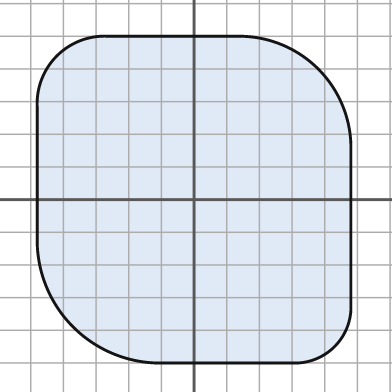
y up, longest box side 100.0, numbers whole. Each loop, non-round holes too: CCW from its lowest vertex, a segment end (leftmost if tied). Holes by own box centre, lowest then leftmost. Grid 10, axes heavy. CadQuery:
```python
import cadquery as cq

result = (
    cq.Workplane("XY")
    .moveTo(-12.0, -50.0)
    .lineTo(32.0, -50.0)
    .threePointArc((43.0, -45.0), (48.0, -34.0))
    .lineTo(48.0, 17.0)
    .threePointArc((38.0, 40.0), (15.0, 50.0))
    .lineTo(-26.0, 50.0)
    .threePointArc((-42.0, 44.0), (-48.0, 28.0))
    .lineTo(-48.0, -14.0)
    .threePointArc((-37.0, -39.0), (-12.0, -50.0))
    .close()
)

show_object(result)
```